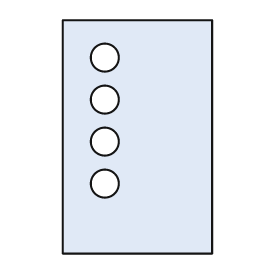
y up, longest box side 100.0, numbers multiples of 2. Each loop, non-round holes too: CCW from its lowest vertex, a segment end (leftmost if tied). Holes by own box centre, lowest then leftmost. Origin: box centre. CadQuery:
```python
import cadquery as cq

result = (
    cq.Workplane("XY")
    .moveTo(-32.0, -50.0)
    .lineTo(32.0, -50.0)
    .lineTo(32.0, 50.0)
    .lineTo(-32.0, 50.0)
    .close()
    .moveTo(-14.0, -20.0)
    .circle(6.0)
    .moveTo(-14.0, -2.0)
    .circle(6.0)
    .moveTo(-14.0, 16.0)
    .circle(6.0)
    .moveTo(-14.0, 34.0)
    .circle(6.0)
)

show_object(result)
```